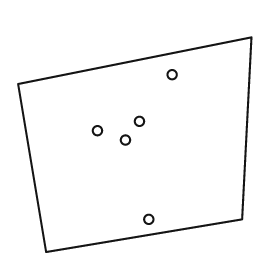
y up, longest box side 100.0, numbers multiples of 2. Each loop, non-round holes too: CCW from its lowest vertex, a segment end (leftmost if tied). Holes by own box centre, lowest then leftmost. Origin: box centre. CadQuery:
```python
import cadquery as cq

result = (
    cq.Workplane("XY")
    .moveTo(-38.0, -46.0)
    .lineTo(46.0, -32.0)
    .lineTo(50.0, 46.0)
    .lineTo(-50.0, 26.0)
    .close()
    .moveTo(6.0, -32.0)
    .circle(2.0)
    .moveTo(-4.0, 2.0)
    .circle(2.0)
    .moveTo(-16.0, 6.0)
    .circle(2.0)
    .moveTo(2.0, 10.0)
    .circle(2.0)
    .moveTo(16.0, 30.0)
    .circle(2.0)
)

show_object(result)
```